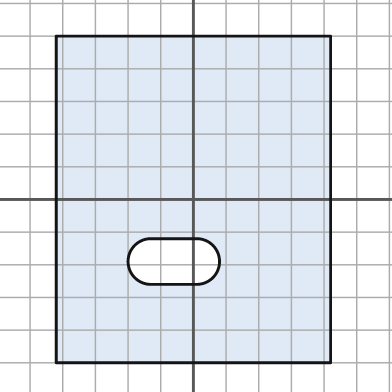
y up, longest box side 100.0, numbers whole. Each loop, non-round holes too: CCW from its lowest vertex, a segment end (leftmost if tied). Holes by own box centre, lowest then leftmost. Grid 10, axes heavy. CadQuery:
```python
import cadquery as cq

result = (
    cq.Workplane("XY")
    .moveTo(-42.0, -50.0)
    .lineTo(42.0, -50.0)
    .lineTo(42.0, 50.0)
    .lineTo(-42.0, 50.0)
    .close()
    .moveTo(-13.0, -26.0)
    .lineTo(1.0, -26.0)
    .threePointArc((8.0, -19.0), (1.0, -12.0))
    .lineTo(-13.0, -12.0)
    .threePointArc((-20.0, -19.0), (-13.0, -26.0))
    .close()
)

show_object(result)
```